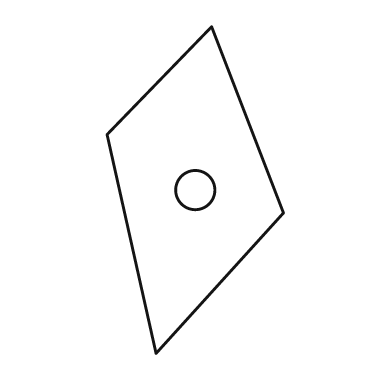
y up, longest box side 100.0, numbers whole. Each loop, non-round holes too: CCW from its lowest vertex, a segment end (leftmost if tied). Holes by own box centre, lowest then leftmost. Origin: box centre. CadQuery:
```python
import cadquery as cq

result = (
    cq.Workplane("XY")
    .moveTo(-12.0, -50.0)
    .lineTo(27.0, -7.0)
    .lineTo(5.0, 50.0)
    .lineTo(-27.0, 17.0)
    .close()
    .moveTo(0.0, 0.0)
    .circle(6.0)
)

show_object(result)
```